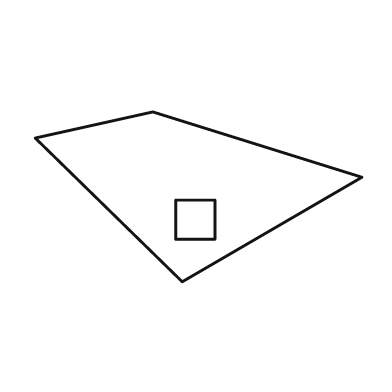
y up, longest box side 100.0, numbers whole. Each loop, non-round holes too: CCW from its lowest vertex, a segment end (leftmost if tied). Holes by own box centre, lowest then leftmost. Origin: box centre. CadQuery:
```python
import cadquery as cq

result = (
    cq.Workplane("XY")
    .moveTo(-5.0, -26.0)
    .lineTo(50.0, 6.0)
    .lineTo(-14.0, 26.0)
    .lineTo(-50.0, 18.0)
    .close()
    .moveTo(-7.0, -13.0)
    .lineTo(5.0, -13.0)
    .lineTo(5.0, -1.0)
    .lineTo(-7.0, -1.0)
    .close()
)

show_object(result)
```